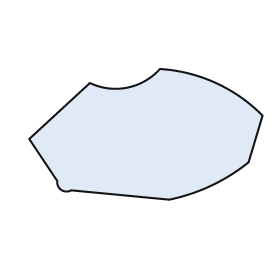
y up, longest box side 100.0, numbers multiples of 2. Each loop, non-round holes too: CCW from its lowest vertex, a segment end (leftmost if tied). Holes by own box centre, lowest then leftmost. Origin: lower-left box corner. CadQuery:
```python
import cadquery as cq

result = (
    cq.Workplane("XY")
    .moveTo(60.0, 0.0)
    .threePointArc((78.0, 6.0), (94.0, 16.0))
    .lineTo(100.0, 36.0)
    .threePointArc((80.0, 50.0), (56.0, 56.0))
    .threePointArc((42.0, 48.0), (26.0, 50.0))
    .lineTo(0.0, 26.0)
    .lineTo(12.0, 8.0)
    .threePointArc((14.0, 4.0), (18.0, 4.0))
    .close()
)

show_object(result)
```